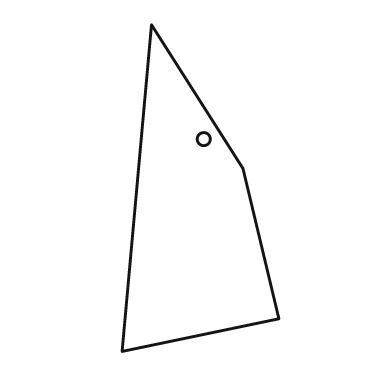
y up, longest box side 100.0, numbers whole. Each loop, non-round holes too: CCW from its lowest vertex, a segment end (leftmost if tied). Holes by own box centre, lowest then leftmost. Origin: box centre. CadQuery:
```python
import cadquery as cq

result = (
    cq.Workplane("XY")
    .moveTo(-24.0, -50.0)
    .lineTo(24.0, -40.0)
    .lineTo(13.0, 6.0)
    .lineTo(-15.0, 50.0)
    .close()
    .moveTo(1.0, 15.0)
    .circle(2.0)
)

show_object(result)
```